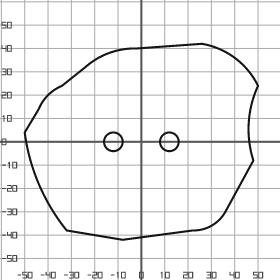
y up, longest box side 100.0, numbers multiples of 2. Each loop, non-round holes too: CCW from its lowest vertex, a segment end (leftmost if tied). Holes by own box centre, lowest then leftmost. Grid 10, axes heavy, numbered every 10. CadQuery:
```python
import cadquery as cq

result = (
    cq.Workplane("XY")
    .moveTo(-8.0, -42.0)
    .lineTo(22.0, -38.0)
    .threePointArc((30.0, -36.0), (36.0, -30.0))
    .lineTo(48.0, -8.0)
    .threePointArc((46.0, 8.0), (50.0, 24.0))
    .threePointArc((40.0, 36.0), (26.0, 42.0))
    .lineTo(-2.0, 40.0)
    .threePointArc((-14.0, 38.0), (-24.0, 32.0))
    .lineTo(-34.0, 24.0)
    .threePointArc((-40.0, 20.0), (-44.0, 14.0))
    .lineTo(-50.0, 4.0)
    .threePointArc((-44.0, -18.0), (-32.0, -38.0))
    .close()
    .moveTo(-12.0, 0.0)
    .circle(4.0)
    .moveTo(12.0, 0.0)
    .circle(4.0)
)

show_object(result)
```